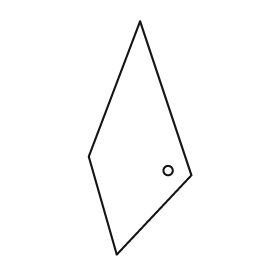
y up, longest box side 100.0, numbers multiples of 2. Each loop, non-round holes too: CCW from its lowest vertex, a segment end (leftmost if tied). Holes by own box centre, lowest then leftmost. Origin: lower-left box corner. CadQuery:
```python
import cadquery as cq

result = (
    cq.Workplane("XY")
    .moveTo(12.0, 0.0)
    .lineTo(44.0, 34.0)
    .lineTo(22.0, 100.0)
    .lineTo(0.0, 42.0)
    .close()
    .moveTo(34.0, 36.0)
    .circle(2.0)
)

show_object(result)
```